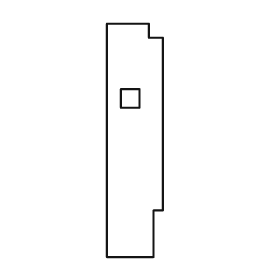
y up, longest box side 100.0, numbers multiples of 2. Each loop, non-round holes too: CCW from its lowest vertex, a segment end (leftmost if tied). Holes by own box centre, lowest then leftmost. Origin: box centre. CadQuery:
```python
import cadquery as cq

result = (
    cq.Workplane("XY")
    .moveTo(-12.0, -50.0)
    .lineTo(8.0, -50.0)
    .lineTo(8.0, -30.0)
    .lineTo(12.0, -30.0)
    .lineTo(12.0, 44.0)
    .lineTo(6.0, 44.0)
    .lineTo(6.0, 50.0)
    .lineTo(-12.0, 50.0)
    .close()
    .moveTo(-6.0, 14.0)
    .lineTo(2.0, 14.0)
    .lineTo(2.0, 22.0)
    .lineTo(-6.0, 22.0)
    .close()
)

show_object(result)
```